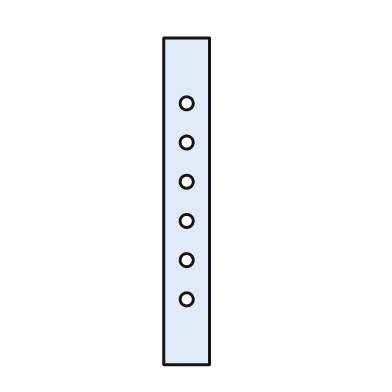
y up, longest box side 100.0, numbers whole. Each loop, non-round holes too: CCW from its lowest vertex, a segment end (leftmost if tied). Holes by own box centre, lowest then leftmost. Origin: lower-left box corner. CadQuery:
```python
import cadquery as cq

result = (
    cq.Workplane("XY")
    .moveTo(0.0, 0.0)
    .lineTo(14.0, 0.0)
    .lineTo(14.0, 100.0)
    .lineTo(0.0, 100.0)
    .close()
    .moveTo(7.0, 20.0)
    .circle(2.0)
    .moveTo(7.0, 32.0)
    .circle(2.0)
    .moveTo(7.0, 44.0)
    .circle(2.0)
    .moveTo(7.0, 56.0)
    .circle(2.0)
    .moveTo(7.0, 68.0)
    .circle(2.0)
    .moveTo(7.0, 80.0)
    .circle(2.0)
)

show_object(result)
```